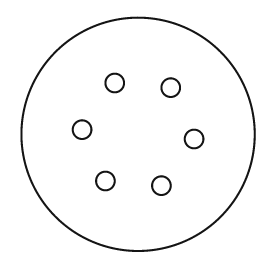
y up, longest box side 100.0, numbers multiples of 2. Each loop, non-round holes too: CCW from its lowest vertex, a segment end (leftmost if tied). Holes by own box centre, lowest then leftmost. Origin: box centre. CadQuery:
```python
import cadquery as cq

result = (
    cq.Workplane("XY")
    .moveTo(0.0, 0.0)
    .circle(50.0)
    .moveTo(10.0, -22.0)
    .circle(4.0)
    .moveTo(-14.0, -20.0)
    .circle(4.0)
    .moveTo(24.0, -2.0)
    .circle(4.0)
    .moveTo(-24.0, 2.0)
    .circle(4.0)
    .moveTo(14.0, 20.0)
    .circle(4.0)
    .moveTo(-10.0, 22.0)
    .circle(4.0)
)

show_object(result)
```